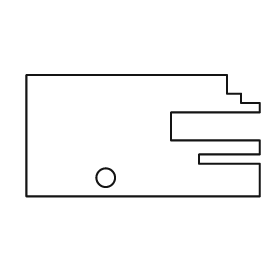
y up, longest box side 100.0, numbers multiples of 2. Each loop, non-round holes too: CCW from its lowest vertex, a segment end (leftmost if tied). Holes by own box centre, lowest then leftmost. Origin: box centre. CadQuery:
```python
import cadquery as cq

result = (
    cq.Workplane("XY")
    .moveTo(-50.0, -26.0)
    .lineTo(50.0, -26.0)
    .lineTo(50.0, -12.0)
    .lineTo(24.0, -12.0)
    .lineTo(24.0, -8.0)
    .lineTo(50.0, -8.0)
    .lineTo(50.0, -2.0)
    .lineTo(12.0, -2.0)
    .lineTo(12.0, 10.0)
    .lineTo(50.0, 10.0)
    .lineTo(50.0, 14.0)
    .lineTo(42.0, 14.0)
    .lineTo(42.0, 18.0)
    .lineTo(36.0, 18.0)
    .lineTo(36.0, 26.0)
    .lineTo(-50.0, 26.0)
    .close()
    .moveTo(-16.0, -18.0)
    .circle(4.0)
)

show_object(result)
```